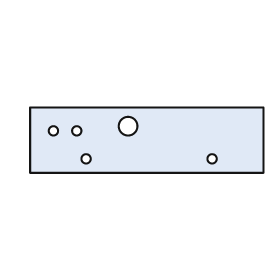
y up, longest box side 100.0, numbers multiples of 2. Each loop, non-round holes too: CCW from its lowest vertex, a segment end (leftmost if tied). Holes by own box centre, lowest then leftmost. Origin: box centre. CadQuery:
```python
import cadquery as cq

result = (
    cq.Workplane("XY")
    .moveTo(-50.0, -14.0)
    .lineTo(50.0, -14.0)
    .lineTo(50.0, 14.0)
    .lineTo(-50.0, 14.0)
    .close()
    .moveTo(-26.0, -8.0)
    .circle(2.0)
    .moveTo(28.0, -8.0)
    .circle(2.0)
    .moveTo(-40.0, 4.0)
    .circle(2.0)
    .moveTo(-30.0, 4.0)
    .circle(2.0)
    .moveTo(-8.0, 6.0)
    .circle(4.0)
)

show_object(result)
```